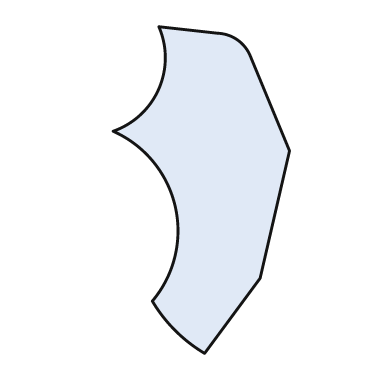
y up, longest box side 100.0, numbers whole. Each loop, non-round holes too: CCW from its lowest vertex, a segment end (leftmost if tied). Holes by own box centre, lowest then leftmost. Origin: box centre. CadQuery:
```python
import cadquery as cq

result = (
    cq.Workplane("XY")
    .moveTo(1.0, -50.0)
    .lineTo(18.0, -27.0)
    .lineTo(27.0, 12.0)
    .lineTo(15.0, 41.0)
    .threePointArc((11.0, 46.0), (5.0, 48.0))
    .lineTo(-13.0, 50.0)
    .threePointArc((-13.0, 31.0), (-27.0, 18.0))
    .threePointArc((-8.0, -5.0), (-15.0, -34.0))
    .threePointArc((-8.0, -43.0), (1.0, -50.0))
    .close()
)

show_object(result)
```